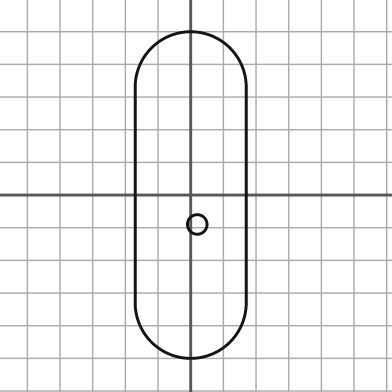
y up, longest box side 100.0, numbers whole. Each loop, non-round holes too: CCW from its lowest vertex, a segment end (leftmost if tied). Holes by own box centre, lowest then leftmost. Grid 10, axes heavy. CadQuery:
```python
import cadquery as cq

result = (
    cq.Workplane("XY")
    .moveTo(-17.0, -33.0)
    .threePointArc((0.0, -50.0), (17.0, -33.0))
    .lineTo(17.0, 33.0)
    .threePointArc((0.0, 50.0), (-17.0, 33.0))
    .close()
    .moveTo(2.0, -9.0)
    .circle(3.0)
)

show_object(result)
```